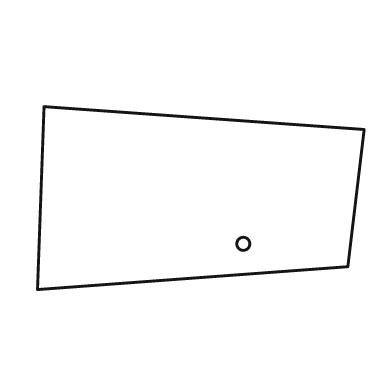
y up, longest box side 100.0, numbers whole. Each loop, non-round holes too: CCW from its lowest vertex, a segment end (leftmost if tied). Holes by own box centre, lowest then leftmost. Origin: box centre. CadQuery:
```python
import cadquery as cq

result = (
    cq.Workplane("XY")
    .moveTo(-50.0, -28.0)
    .lineTo(45.0, -21.0)
    .lineTo(50.0, 21.0)
    .lineTo(-48.0, 28.0)
    .close()
    .moveTo(13.0, -14.0)
    .circle(2.0)
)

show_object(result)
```